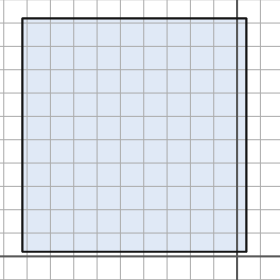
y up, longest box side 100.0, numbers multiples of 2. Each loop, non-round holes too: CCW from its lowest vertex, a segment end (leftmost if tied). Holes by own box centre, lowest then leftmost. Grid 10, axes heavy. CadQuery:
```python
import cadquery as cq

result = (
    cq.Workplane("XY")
    .moveTo(-92.0, 2.0)
    .lineTo(4.0, 2.0)
    .lineTo(4.0, 102.0)
    .lineTo(-92.0, 102.0)
    .close()
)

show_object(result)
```